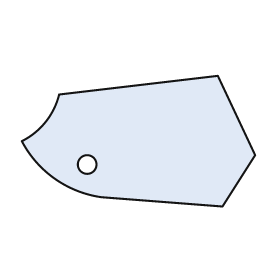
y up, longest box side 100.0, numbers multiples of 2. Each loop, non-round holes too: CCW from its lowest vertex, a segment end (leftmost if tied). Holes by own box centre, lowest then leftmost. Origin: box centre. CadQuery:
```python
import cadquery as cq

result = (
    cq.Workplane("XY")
    .moveTo(36.0, -28.0)
    .lineTo(50.0, -6.0)
    .lineTo(34.0, 28.0)
    .lineTo(-34.0, 20.0)
    .threePointArc((-40.0, 8.0), (-50.0, 0.0))
    .threePointArc((-36.0, -16.0), (-16.0, -24.0))
    .close()
    .moveTo(-22.0, -10.0)
    .circle(4.0)
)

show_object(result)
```